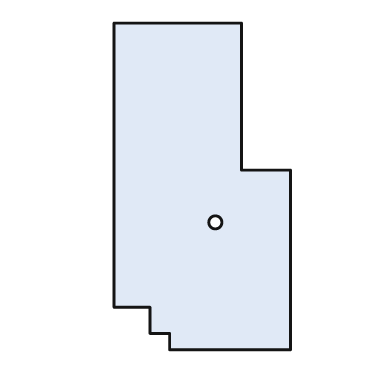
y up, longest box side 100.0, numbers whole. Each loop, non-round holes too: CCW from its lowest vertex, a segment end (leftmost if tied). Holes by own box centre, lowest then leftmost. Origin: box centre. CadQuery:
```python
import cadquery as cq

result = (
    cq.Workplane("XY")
    .moveTo(-10.0, -50.0)
    .lineTo(27.0, -50.0)
    .lineTo(27.0, 5.0)
    .lineTo(12.0, 5.0)
    .lineTo(12.0, 50.0)
    .lineTo(-27.0, 50.0)
    .lineTo(-27.0, -37.0)
    .lineTo(-16.0, -37.0)
    .lineTo(-16.0, -45.0)
    .lineTo(-10.0, -45.0)
    .close()
    .moveTo(4.0, -11.0)
    .circle(2.0)
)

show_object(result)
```